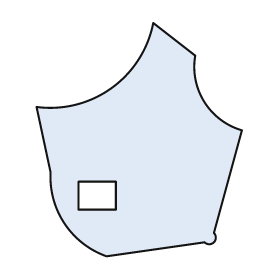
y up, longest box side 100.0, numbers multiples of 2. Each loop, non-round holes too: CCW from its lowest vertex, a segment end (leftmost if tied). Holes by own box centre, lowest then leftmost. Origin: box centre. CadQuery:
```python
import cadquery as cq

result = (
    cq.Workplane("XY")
    .moveTo(-14.0, -50.0)
    .lineTo(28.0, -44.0)
    .threePointArc((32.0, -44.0), (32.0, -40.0))
    .lineTo(44.0, 4.0)
    .threePointArc((28.0, 16.0), (24.0, 36.0))
    .lineTo(6.0, 50.0)
    .threePointArc((-12.0, 22.0), (-44.0, 14.0))
    .lineTo(-38.0, -14.0)
    .threePointArc((-32.0, -36.0), (-14.0, -50.0))
    .close()
    .moveTo(-26.0, -30.0)
    .lineTo(-10.0, -30.0)
    .lineTo(-10.0, -18.0)
    .lineTo(-26.0, -18.0)
    .close()
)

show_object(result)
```